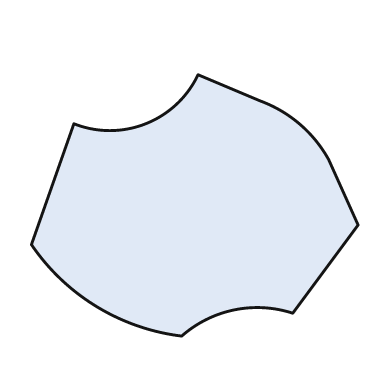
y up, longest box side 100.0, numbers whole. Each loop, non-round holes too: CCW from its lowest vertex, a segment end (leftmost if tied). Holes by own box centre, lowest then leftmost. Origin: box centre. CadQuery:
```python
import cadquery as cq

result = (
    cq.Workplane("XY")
    .moveTo(-4.0, -40.0)
    .threePointArc((12.0, -32.0), (30.0, -33.0))
    .lineTo(50.0, -6.0)
    .lineTo(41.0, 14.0)
    .threePointArc((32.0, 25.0), (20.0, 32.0))
    .lineTo(1.0, 40.0)
    .threePointArc((-15.0, 25.0), (-37.0, 25.0))
    .lineTo(-50.0, -12.0)
    .threePointArc((-30.0, -31.0), (-4.0, -40.0))
    .close()
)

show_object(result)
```